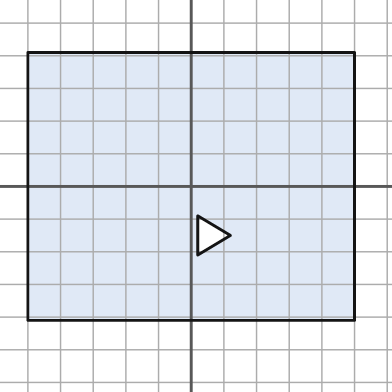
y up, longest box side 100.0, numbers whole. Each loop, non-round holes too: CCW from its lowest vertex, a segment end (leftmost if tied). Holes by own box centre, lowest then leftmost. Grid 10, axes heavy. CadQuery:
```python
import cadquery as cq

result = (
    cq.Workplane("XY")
    .moveTo(-50.0, -41.0)
    .lineTo(50.0, -41.0)
    .lineTo(50.0, 41.0)
    .lineTo(-50.0, 41.0)
    .close()
    .moveTo(2.0, -21.0)
    .lineTo(12.0, -15.0)
    .lineTo(2.0, -9.0)
    .close()
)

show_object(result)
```